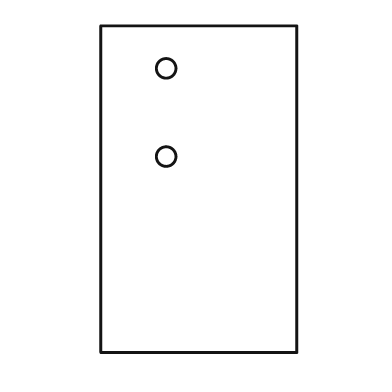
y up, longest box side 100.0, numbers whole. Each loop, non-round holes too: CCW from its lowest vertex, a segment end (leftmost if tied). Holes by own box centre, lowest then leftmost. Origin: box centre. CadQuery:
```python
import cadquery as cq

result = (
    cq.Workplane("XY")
    .moveTo(-30.0, -50.0)
    .lineTo(30.0, -50.0)
    .lineTo(30.0, 50.0)
    .lineTo(-30.0, 50.0)
    .close()
    .moveTo(-10.0, 10.0)
    .circle(3.0)
    .moveTo(-10.0, 37.0)
    .circle(3.0)
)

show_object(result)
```